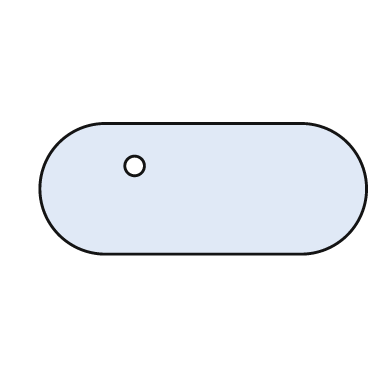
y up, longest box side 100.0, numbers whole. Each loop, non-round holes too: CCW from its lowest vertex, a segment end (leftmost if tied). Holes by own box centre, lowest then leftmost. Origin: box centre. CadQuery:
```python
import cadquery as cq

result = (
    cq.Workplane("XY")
    .moveTo(-30.0, -20.0)
    .lineTo(30.0, -20.0)
    .threePointArc((50.0, 0.0), (30.0, 20.0))
    .lineTo(-30.0, 20.0)
    .threePointArc((-50.0, 0.0), (-30.0, -20.0))
    .close()
    .moveTo(-21.0, 7.0)
    .circle(3.0)
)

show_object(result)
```